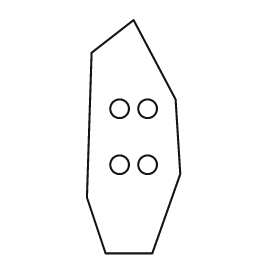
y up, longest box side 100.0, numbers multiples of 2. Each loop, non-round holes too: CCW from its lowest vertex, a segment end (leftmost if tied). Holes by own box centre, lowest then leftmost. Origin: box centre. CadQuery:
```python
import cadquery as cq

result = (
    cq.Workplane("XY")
    .moveTo(-12.0, -50.0)
    .lineTo(8.0, -50.0)
    .lineTo(20.0, -16.0)
    .lineTo(18.0, 16.0)
    .lineTo(0.0, 50.0)
    .lineTo(-18.0, 36.0)
    .lineTo(-20.0, -26.0)
    .close()
    .moveTo(-6.0, -12.0)
    .circle(4.0)
    .moveTo(6.0, -12.0)
    .circle(4.0)
    .moveTo(-6.0, 12.0)
    .circle(4.0)
    .moveTo(6.0, 12.0)
    .circle(4.0)
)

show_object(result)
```